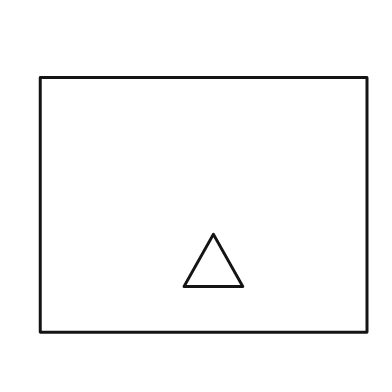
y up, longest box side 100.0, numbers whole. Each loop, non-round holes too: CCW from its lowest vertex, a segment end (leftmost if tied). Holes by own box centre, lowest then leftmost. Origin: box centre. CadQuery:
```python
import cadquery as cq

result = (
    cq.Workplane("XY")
    .moveTo(-50.0, -39.0)
    .lineTo(50.0, -39.0)
    .lineTo(50.0, 39.0)
    .lineTo(-50.0, 39.0)
    .close()
    .moveTo(-6.0, -25.0)
    .lineTo(12.0, -25.0)
    .lineTo(3.0, -9.0)
    .close()
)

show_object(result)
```